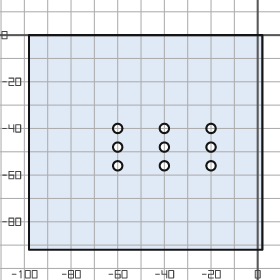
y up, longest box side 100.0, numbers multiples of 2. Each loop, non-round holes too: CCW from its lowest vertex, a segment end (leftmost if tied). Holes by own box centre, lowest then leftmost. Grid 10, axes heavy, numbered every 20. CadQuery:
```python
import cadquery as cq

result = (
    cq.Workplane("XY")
    .moveTo(-98.0, -92.0)
    .lineTo(2.0, -92.0)
    .lineTo(2.0, 0.0)
    .lineTo(-98.0, 0.0)
    .close()
    .moveTo(-60.0, -56.0)
    .circle(2.0)
    .moveTo(-40.0, -56.0)
    .circle(2.0)
    .moveTo(-20.0, -56.0)
    .circle(2.0)
    .moveTo(-60.0, -48.0)
    .circle(2.0)
    .moveTo(-40.0, -48.0)
    .circle(2.0)
    .moveTo(-20.0, -48.0)
    .circle(2.0)
    .moveTo(-60.0, -40.0)
    .circle(2.0)
    .moveTo(-40.0, -40.0)
    .circle(2.0)
    .moveTo(-20.0, -40.0)
    .circle(2.0)
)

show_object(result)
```